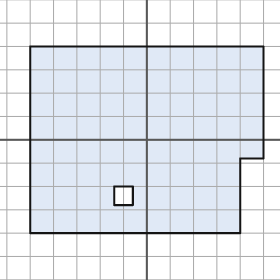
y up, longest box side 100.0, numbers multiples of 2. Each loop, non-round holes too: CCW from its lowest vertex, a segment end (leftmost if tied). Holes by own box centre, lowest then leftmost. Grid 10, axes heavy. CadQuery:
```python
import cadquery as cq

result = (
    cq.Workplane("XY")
    .moveTo(-50.0, -40.0)
    .lineTo(40.0, -40.0)
    .lineTo(40.0, -8.0)
    .lineTo(50.0, -8.0)
    .lineTo(50.0, 40.0)
    .lineTo(-50.0, 40.0)
    .close()
    .moveTo(-14.0, -28.0)
    .lineTo(-6.0, -28.0)
    .lineTo(-6.0, -20.0)
    .lineTo(-14.0, -20.0)
    .close()
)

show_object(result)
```